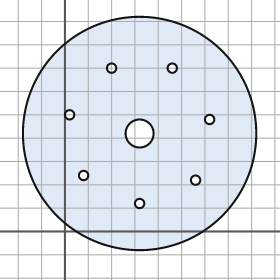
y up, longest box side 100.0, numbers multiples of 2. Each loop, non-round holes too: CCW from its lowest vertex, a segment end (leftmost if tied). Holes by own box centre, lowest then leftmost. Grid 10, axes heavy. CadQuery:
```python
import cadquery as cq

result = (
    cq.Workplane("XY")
    .moveTo(32.0, 42.0)
    .circle(50.0)
    .moveTo(32.0, 12.0)
    .circle(2.0)
    .moveTo(56.0, 22.0)
    .circle(2.0)
    .moveTo(8.0, 24.0)
    .circle(2.0)
    .moveTo(32.0, 42.0)
    .circle(6.0)
    .moveTo(62.0, 48.0)
    .circle(2.0)
    .moveTo(2.0, 50.0)
    .circle(2.0)
    .moveTo(20.0, 70.0)
    .circle(2.0)
    .moveTo(46.0, 70.0)
    .circle(2.0)
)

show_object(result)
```